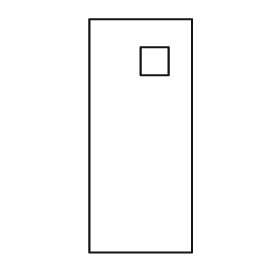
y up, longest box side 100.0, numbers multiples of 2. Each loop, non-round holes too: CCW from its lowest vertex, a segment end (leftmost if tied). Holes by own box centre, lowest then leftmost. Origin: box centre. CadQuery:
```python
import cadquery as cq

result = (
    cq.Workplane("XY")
    .moveTo(-22.0, -50.0)
    .lineTo(22.0, -50.0)
    .lineTo(22.0, 50.0)
    .lineTo(-22.0, 50.0)
    .close()
    .moveTo(0.0, 26.0)
    .lineTo(12.0, 26.0)
    .lineTo(12.0, 38.0)
    .lineTo(0.0, 38.0)
    .close()
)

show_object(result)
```